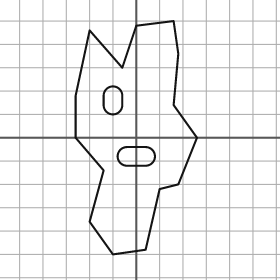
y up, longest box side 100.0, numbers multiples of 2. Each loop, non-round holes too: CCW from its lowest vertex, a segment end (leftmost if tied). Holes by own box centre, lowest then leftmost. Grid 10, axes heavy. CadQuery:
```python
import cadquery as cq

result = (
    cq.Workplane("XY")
    .moveTo(-10.0, -50.0)
    .lineTo(4.0, -48.0)
    .lineTo(10.0, -22.0)
    .lineTo(18.0, -20.0)
    .lineTo(26.0, 0.0)
    .lineTo(16.0, 14.0)
    .lineTo(18.0, 36.0)
    .lineTo(16.0, 50.0)
    .lineTo(0.0, 48.0)
    .lineTo(-6.0, 30.0)
    .lineTo(-20.0, 46.0)
    .lineTo(-26.0, 18.0)
    .lineTo(-26.0, 0.0)
    .lineTo(-14.0, -14.0)
    .lineTo(-20.0, -36.0)
    .close()
    .moveTo(-4.0, -12.0)
    .lineTo(4.0, -12.0)
    .threePointArc((8.0, -8.0), (4.0, -4.0))
    .lineTo(-4.0, -4.0)
    .threePointArc((-8.0, -8.0), (-4.0, -12.0))
    .close()
    .moveTo(-14.0, 14.0)
    .threePointArc((-10.0, 10.0), (-6.0, 14.0))
    .lineTo(-6.0, 18.0)
    .threePointArc((-10.0, 22.0), (-14.0, 18.0))
    .close()
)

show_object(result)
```